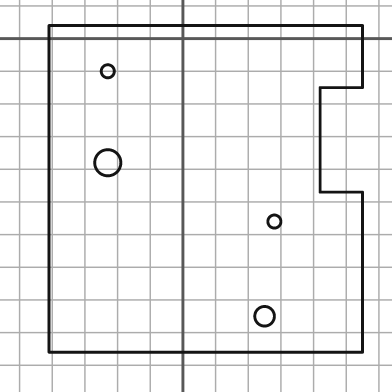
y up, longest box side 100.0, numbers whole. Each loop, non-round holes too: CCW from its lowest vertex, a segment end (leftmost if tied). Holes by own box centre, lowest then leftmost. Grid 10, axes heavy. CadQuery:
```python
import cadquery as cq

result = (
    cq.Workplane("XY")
    .moveTo(-41.0, -96.0)
    .lineTo(55.0, -96.0)
    .lineTo(55.0, -47.0)
    .lineTo(42.0, -47.0)
    .lineTo(42.0, -15.0)
    .lineTo(55.0, -15.0)
    .lineTo(55.0, 4.0)
    .lineTo(-41.0, 4.0)
    .close()
    .moveTo(25.0, -85.0)
    .circle(3.0)
    .moveTo(28.0, -56.0)
    .circle(2.0)
    .moveTo(-23.0, -38.0)
    .circle(4.0)
    .moveTo(-23.0, -10.0)
    .circle(2.0)
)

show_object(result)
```